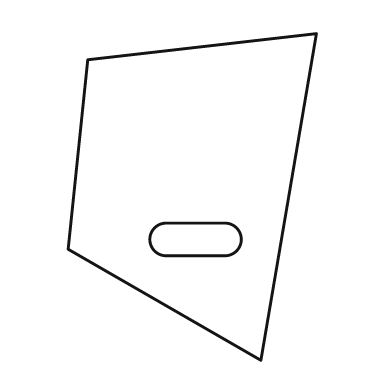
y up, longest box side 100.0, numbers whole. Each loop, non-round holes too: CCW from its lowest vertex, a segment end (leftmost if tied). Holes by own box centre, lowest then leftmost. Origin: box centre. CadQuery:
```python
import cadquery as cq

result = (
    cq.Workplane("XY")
    .moveTo(21.0, -50.0)
    .lineTo(38.0, 50.0)
    .lineTo(-32.0, 42.0)
    .lineTo(-38.0, -16.0)
    .close()
    .moveTo(-8.0, -18.0)
    .lineTo(10.0, -18.0)
    .threePointArc((15.0, -13.0), (10.0, -8.0))
    .lineTo(-8.0, -8.0)
    .threePointArc((-13.0, -13.0), (-8.0, -18.0))
    .close()
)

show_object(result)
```